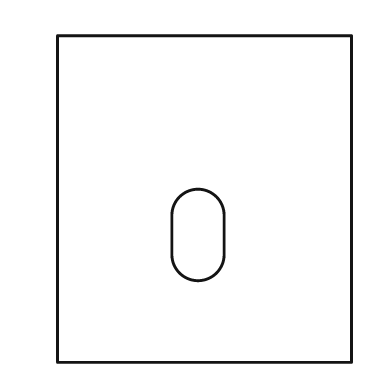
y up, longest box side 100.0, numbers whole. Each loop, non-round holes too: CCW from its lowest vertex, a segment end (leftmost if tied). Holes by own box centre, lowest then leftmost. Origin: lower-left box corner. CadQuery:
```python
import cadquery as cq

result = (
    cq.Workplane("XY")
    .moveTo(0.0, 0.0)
    .lineTo(90.0, 0.0)
    .lineTo(90.0, 100.0)
    .lineTo(0.0, 100.0)
    .close()
    .moveTo(35.0, 33.0)
    .threePointArc((43.0, 25.0), (51.0, 33.0))
    .lineTo(51.0, 45.0)
    .threePointArc((43.0, 53.0), (35.0, 45.0))
    .close()
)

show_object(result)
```